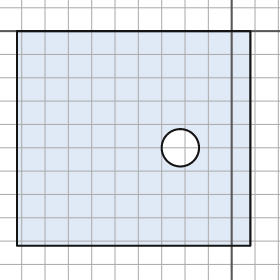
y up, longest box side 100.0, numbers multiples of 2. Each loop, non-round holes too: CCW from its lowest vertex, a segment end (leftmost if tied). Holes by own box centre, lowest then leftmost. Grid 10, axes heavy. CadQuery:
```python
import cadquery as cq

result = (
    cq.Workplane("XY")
    .moveTo(-92.0, -92.0)
    .lineTo(8.0, -92.0)
    .lineTo(8.0, 0.0)
    .lineTo(-92.0, 0.0)
    .close()
    .moveTo(-22.0, -50.0)
    .circle(8.0)
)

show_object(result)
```